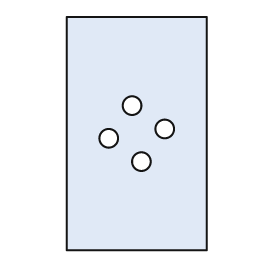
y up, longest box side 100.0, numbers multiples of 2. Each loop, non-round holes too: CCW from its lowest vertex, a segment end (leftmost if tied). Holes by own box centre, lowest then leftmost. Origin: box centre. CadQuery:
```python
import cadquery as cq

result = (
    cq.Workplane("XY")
    .moveTo(-30.0, -50.0)
    .lineTo(30.0, -50.0)
    .lineTo(30.0, 50.0)
    .lineTo(-30.0, 50.0)
    .close()
    .moveTo(2.0, -12.0)
    .circle(4.0)
    .moveTo(-12.0, -2.0)
    .circle(4.0)
    .moveTo(12.0, 2.0)
    .circle(4.0)
    .moveTo(-2.0, 12.0)
    .circle(4.0)
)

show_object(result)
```